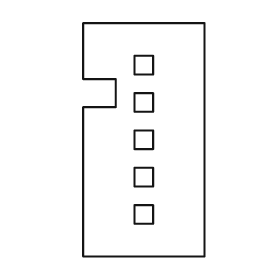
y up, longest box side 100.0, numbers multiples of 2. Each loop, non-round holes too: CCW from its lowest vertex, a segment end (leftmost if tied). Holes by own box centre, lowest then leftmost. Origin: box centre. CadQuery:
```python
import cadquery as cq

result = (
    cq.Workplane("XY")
    .moveTo(-26.0, -50.0)
    .lineTo(26.0, -50.0)
    .lineTo(26.0, 50.0)
    .lineTo(-26.0, 50.0)
    .lineTo(-26.0, 26.0)
    .lineTo(-12.0, 26.0)
    .lineTo(-12.0, 14.0)
    .lineTo(-26.0, 14.0)
    .close()
    .moveTo(-4.0, -36.0)
    .lineTo(4.0, -36.0)
    .lineTo(4.0, -28.0)
    .lineTo(-4.0, -28.0)
    .close()
    .moveTo(-4.0, -20.0)
    .lineTo(4.0, -20.0)
    .lineTo(4.0, -12.0)
    .lineTo(-4.0, -12.0)
    .close()
    .moveTo(-4.0, -4.0)
    .lineTo(4.0, -4.0)
    .lineTo(4.0, 4.0)
    .lineTo(-4.0, 4.0)
    .close()
    .moveTo(-4.0, 12.0)
    .lineTo(4.0, 12.0)
    .lineTo(4.0, 20.0)
    .lineTo(-4.0, 20.0)
    .close()
    .moveTo(-4.0, 28.0)
    .lineTo(4.0, 28.0)
    .lineTo(4.0, 36.0)
    .lineTo(-4.0, 36.0)
    .close()
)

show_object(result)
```